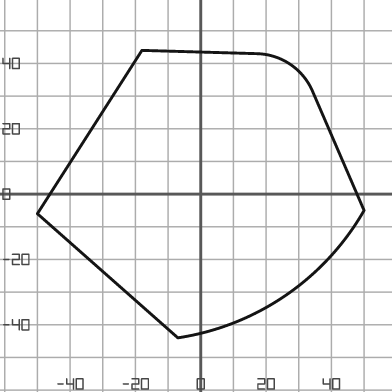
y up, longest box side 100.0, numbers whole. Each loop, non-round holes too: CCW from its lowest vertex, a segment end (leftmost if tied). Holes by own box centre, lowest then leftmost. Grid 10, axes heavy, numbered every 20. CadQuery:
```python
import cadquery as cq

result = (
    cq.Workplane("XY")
    .moveTo(-7.0, -44.0)
    .threePointArc((26.0, -31.0), (50.0, -5.0))
    .lineTo(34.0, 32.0)
    .threePointArc((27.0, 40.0), (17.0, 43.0))
    .lineTo(-18.0, 44.0)
    .lineTo(-50.0, -6.0)
    .close()
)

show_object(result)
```